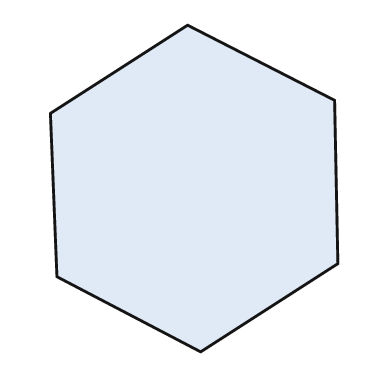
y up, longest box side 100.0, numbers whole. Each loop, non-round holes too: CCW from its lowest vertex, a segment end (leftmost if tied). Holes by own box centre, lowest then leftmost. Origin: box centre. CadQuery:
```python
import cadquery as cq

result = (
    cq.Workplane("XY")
    .moveTo(2.0, -50.0)
    .lineTo(44.0, -23.0)
    .lineTo(43.0, 27.0)
    .lineTo(-2.0, 50.0)
    .lineTo(-44.0, 23.0)
    .lineTo(-42.0, -27.0)
    .close()
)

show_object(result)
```